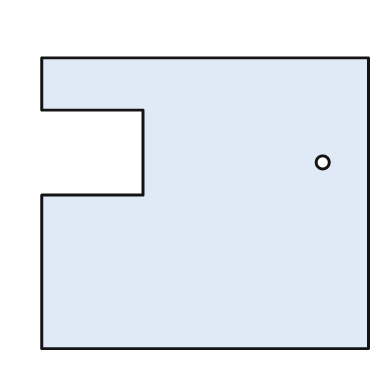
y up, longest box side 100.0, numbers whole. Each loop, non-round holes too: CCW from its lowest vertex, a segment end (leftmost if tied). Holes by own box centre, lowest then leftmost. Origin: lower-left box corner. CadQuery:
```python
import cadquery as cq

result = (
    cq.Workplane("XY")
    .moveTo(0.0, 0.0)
    .lineTo(100.0, 0.0)
    .lineTo(100.0, 89.0)
    .lineTo(0.0, 89.0)
    .lineTo(0.0, 73.0)
    .lineTo(31.0, 73.0)
    .lineTo(31.0, 47.0)
    .lineTo(0.0, 47.0)
    .close()
    .moveTo(86.0, 57.0)
    .circle(2.0)
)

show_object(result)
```